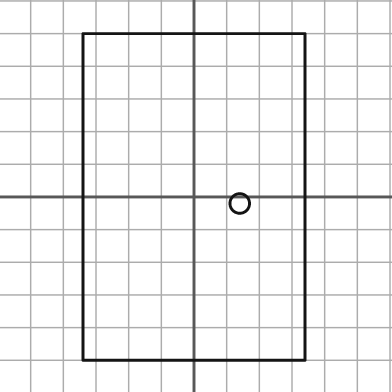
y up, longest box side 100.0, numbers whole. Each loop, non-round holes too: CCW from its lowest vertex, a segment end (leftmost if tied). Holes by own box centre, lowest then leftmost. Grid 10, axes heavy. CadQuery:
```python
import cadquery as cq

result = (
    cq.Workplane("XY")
    .moveTo(-34.0, -50.0)
    .lineTo(34.0, -50.0)
    .lineTo(34.0, 50.0)
    .lineTo(-34.0, 50.0)
    .close()
    .moveTo(14.0, -2.0)
    .circle(3.0)
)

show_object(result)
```